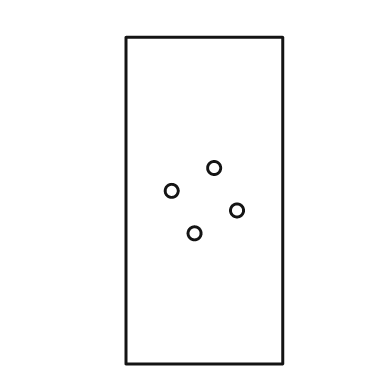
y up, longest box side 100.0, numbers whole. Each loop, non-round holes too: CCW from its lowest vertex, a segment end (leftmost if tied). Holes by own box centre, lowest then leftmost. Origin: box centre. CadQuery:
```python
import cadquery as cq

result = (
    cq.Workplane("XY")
    .moveTo(-24.0, -50.0)
    .lineTo(24.0, -50.0)
    .lineTo(24.0, 50.0)
    .lineTo(-24.0, 50.0)
    .close()
    .moveTo(-3.0, -10.0)
    .circle(2.0)
    .moveTo(10.0, -3.0)
    .circle(2.0)
    .moveTo(-10.0, 3.0)
    .circle(2.0)
    .moveTo(3.0, 10.0)
    .circle(2.0)
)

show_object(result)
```